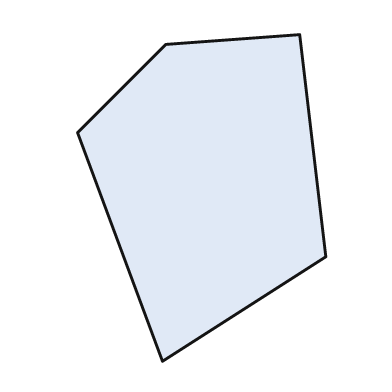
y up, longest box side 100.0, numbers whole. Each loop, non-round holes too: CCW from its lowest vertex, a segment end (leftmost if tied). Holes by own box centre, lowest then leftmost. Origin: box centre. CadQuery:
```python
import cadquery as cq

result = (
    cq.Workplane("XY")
    .moveTo(-12.0, -50.0)
    .lineTo(38.0, -18.0)
    .lineTo(30.0, 50.0)
    .lineTo(-11.0, 47.0)
    .lineTo(-38.0, 20.0)
    .close()
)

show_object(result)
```